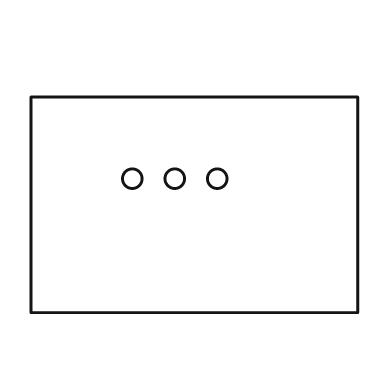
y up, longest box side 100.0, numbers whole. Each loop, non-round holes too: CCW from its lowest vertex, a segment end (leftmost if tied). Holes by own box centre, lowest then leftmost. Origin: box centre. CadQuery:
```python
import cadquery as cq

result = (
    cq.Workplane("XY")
    .moveTo(-50.0, -33.0)
    .lineTo(50.0, -33.0)
    .lineTo(50.0, 33.0)
    .lineTo(-50.0, 33.0)
    .close()
    .moveTo(-19.0, 8.0)
    .circle(3.0)
    .moveTo(-6.0, 8.0)
    .circle(3.0)
    .moveTo(7.0, 8.0)
    .circle(3.0)
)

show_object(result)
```